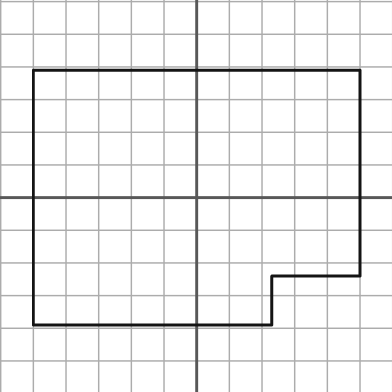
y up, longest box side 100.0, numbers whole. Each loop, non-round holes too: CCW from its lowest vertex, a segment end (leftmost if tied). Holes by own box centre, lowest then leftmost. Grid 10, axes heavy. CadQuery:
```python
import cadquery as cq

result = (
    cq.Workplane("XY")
    .moveTo(-50.0, -39.0)
    .lineTo(23.0, -39.0)
    .lineTo(23.0, -24.0)
    .lineTo(50.0, -24.0)
    .lineTo(50.0, 39.0)
    .lineTo(-50.0, 39.0)
    .close()
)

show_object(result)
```